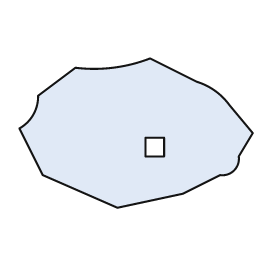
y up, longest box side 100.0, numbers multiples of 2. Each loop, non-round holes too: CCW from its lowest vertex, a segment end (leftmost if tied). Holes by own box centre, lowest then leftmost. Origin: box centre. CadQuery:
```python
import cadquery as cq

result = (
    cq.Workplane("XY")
    .moveTo(-8.0, -32.0)
    .lineTo(20.0, -26.0)
    .lineTo(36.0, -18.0)
    .threePointArc((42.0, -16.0), (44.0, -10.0))
    .lineTo(50.0, 0.0)
    .lineTo(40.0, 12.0)
    .threePointArc((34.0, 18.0), (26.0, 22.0))
    .lineTo(6.0, 32.0)
    .threePointArc((-10.0, 28.0), (-26.0, 28.0))
    .lineTo(-42.0, 16.0)
    .threePointArc((-44.0, 8.0), (-50.0, 2.0))
    .lineTo(-40.0, -18.0)
    .close()
    .moveTo(4.0, -10.0)
    .lineTo(12.0, -10.0)
    .lineTo(12.0, -2.0)
    .lineTo(4.0, -2.0)
    .close()
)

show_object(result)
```